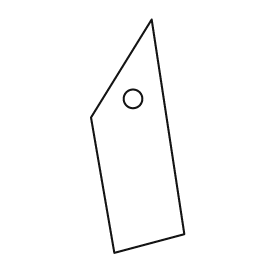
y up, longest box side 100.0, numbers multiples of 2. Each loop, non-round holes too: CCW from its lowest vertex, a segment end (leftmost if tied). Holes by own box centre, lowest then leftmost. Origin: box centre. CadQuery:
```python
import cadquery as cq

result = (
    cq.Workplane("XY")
    .moveTo(-10.0, -50.0)
    .lineTo(20.0, -42.0)
    .lineTo(6.0, 50.0)
    .lineTo(-20.0, 8.0)
    .close()
    .moveTo(-2.0, 16.0)
    .circle(4.0)
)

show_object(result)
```